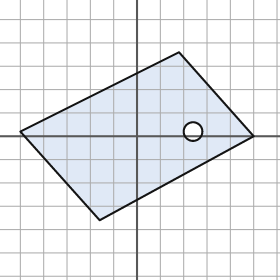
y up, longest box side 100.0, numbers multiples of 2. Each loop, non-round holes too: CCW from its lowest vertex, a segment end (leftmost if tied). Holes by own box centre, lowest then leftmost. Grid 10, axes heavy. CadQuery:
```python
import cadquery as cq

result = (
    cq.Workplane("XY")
    .moveTo(-16.0, -36.0)
    .lineTo(50.0, 0.0)
    .lineTo(18.0, 36.0)
    .lineTo(-50.0, 2.0)
    .close()
    .moveTo(24.0, 2.0)
    .circle(4.0)
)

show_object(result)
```